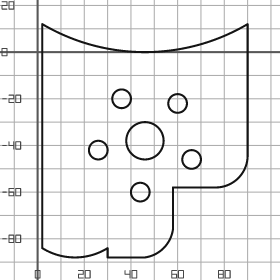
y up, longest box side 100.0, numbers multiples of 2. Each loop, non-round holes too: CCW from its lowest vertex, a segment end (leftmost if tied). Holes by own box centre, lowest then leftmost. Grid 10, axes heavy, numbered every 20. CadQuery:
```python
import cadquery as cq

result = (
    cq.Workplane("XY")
    .moveTo(30.0, -88.0)
    .lineTo(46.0, -88.0)
    .threePointArc((54.0, -84.0), (58.0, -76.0))
    .lineTo(58.0, -58.0)
    .lineTo(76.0, -58.0)
    .threePointArc((86.0, -54.0), (90.0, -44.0))
    .lineTo(90.0, 12.0)
    .threePointArc((46.0, 0.0), (2.0, 12.0))
    .lineTo(2.0, -84.0)
    .threePointArc((16.0, -88.0), (30.0, -84.0))
    .close()
    .moveTo(44.0, -60.0)
    .circle(4.0)
    .moveTo(66.0, -46.0)
    .circle(4.0)
    .moveTo(26.0, -42.0)
    .circle(4.0)
    .moveTo(46.0, -38.0)
    .circle(8.0)
    .moveTo(60.0, -22.0)
    .circle(4.0)
    .moveTo(36.0, -20.0)
    .circle(4.0)
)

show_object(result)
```